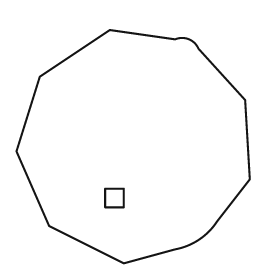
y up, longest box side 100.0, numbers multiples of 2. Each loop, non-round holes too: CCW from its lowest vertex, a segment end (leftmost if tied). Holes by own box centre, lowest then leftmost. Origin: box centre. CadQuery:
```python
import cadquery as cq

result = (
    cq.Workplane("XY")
    .moveTo(-4.0, -50.0)
    .lineTo(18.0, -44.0)
    .threePointArc((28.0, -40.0), (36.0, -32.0))
    .lineTo(50.0, -14.0)
    .lineTo(48.0, 20.0)
    .lineTo(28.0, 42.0)
    .threePointArc((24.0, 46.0), (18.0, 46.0))
    .lineTo(-10.0, 50.0)
    .lineTo(-40.0, 30.0)
    .lineTo(-50.0, -2.0)
    .lineTo(-36.0, -34.0)
    .close()
    .moveTo(-12.0, -26.0)
    .lineTo(-4.0, -26.0)
    .lineTo(-4.0, -18.0)
    .lineTo(-12.0, -18.0)
    .close()
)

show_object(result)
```